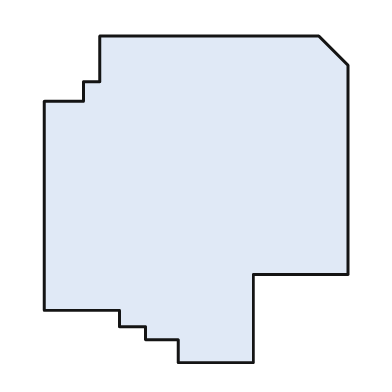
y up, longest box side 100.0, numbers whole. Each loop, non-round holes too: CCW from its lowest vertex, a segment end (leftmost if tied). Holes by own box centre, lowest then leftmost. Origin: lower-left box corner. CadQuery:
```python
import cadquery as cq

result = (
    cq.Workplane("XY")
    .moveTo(41.0, 0.0)
    .lineTo(64.0, 0.0)
    .lineTo(64.0, 27.0)
    .lineTo(93.0, 27.0)
    .lineTo(93.0, 91.0)
    .lineTo(84.0, 100.0)
    .lineTo(17.0, 100.0)
    .lineTo(17.0, 86.0)
    .lineTo(12.0, 86.0)
    .lineTo(12.0, 80.0)
    .lineTo(0.0, 80.0)
    .lineTo(0.0, 16.0)
    .lineTo(23.0, 16.0)
    .lineTo(23.0, 11.0)
    .lineTo(31.0, 11.0)
    .lineTo(31.0, 7.0)
    .lineTo(41.0, 7.0)
    .close()
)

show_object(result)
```